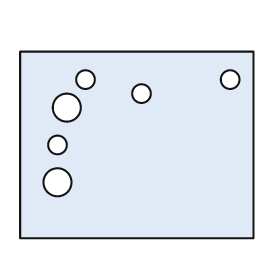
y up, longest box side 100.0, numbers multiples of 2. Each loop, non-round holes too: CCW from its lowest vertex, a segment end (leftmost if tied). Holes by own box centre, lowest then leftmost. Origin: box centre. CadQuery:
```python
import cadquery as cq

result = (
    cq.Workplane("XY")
    .moveTo(-50.0, -40.0)
    .lineTo(50.0, -40.0)
    .lineTo(50.0, 40.0)
    .lineTo(-50.0, 40.0)
    .close()
    .moveTo(-34.0, -16.0)
    .circle(6.0)
    .moveTo(-34.0, 0.0)
    .circle(4.0)
    .moveTo(-30.0, 16.0)
    .circle(6.0)
    .moveTo(2.0, 22.0)
    .circle(4.0)
    .moveTo(-22.0, 28.0)
    .circle(4.0)
    .moveTo(40.0, 28.0)
    .circle(4.0)
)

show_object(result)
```